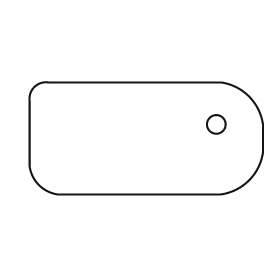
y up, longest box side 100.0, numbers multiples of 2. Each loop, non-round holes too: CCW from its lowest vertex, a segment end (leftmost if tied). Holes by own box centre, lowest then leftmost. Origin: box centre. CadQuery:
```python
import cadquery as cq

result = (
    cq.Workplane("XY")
    .moveTo(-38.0, -24.0)
    .lineTo(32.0, -24.0)
    .threePointArc((44.0, -18.0), (50.0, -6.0))
    .lineTo(50.0, 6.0)
    .threePointArc((44.0, 18.0), (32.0, 24.0))
    .lineTo(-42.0, 24.0)
    .threePointArc((-48.0, 22.0), (-50.0, 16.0))
    .lineTo(-50.0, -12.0)
    .threePointArc((-46.0, -20.0), (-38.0, -24.0))
    .close()
    .moveTo(30.0, 6.0)
    .circle(4.0)
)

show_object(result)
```